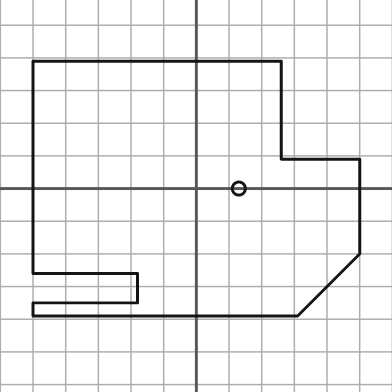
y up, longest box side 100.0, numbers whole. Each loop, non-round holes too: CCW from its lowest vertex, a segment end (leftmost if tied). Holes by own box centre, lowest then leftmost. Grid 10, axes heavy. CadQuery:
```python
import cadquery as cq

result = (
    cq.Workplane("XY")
    .moveTo(-50.0, -39.0)
    .lineTo(31.0, -39.0)
    .lineTo(50.0, -20.0)
    .lineTo(50.0, 9.0)
    .lineTo(26.0, 9.0)
    .lineTo(26.0, 39.0)
    .lineTo(-50.0, 39.0)
    .lineTo(-50.0, -26.0)
    .lineTo(-18.0, -26.0)
    .lineTo(-18.0, -35.0)
    .lineTo(-50.0, -35.0)
    .close()
    .moveTo(13.0, 0.0)
    .circle(2.0)
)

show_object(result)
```